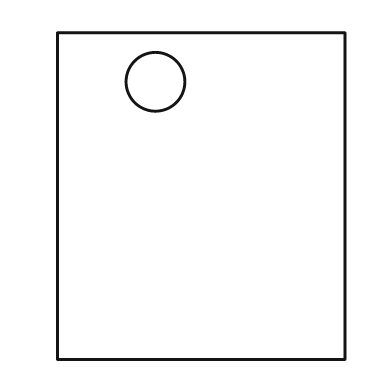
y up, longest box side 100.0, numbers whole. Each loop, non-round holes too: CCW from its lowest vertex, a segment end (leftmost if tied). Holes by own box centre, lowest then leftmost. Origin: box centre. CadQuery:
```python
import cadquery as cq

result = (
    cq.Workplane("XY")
    .moveTo(-44.0, -50.0)
    .lineTo(44.0, -50.0)
    .lineTo(44.0, 50.0)
    .lineTo(-44.0, 50.0)
    .close()
    .moveTo(-14.0, 35.0)
    .circle(9.0)
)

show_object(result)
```